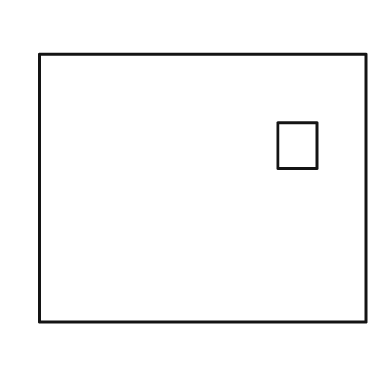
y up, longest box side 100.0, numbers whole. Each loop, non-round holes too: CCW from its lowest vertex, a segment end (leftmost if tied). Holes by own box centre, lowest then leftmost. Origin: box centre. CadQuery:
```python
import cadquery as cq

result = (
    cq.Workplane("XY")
    .moveTo(-50.0, -41.0)
    .lineTo(50.0, -41.0)
    .lineTo(50.0, 41.0)
    .lineTo(-50.0, 41.0)
    .close()
    .moveTo(23.0, 6.0)
    .lineTo(35.0, 6.0)
    .lineTo(35.0, 20.0)
    .lineTo(23.0, 20.0)
    .close()
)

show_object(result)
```